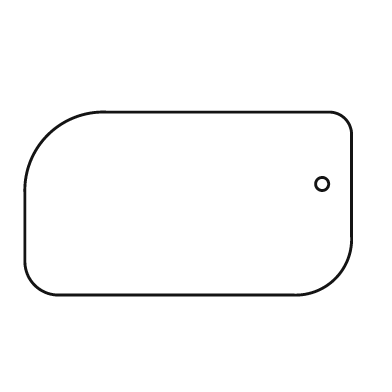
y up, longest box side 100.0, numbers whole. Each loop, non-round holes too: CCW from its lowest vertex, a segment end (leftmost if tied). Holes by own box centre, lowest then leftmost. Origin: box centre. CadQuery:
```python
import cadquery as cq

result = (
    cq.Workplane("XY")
    .moveTo(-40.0, -28.0)
    .lineTo(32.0, -28.0)
    .threePointArc((45.0, -23.0), (50.0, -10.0))
    .lineTo(50.0, 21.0)
    .threePointArc((48.0, 26.0), (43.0, 28.0))
    .lineTo(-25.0, 28.0)
    .threePointArc((-43.0, 21.0), (-50.0, 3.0))
    .lineTo(-50.0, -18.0)
    .threePointArc((-47.0, -25.0), (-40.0, -28.0))
    .close()
    .moveTo(41.0, 6.0)
    .circle(2.0)
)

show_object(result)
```